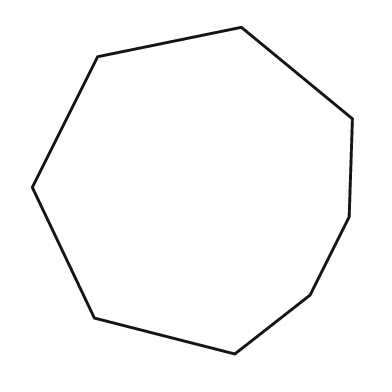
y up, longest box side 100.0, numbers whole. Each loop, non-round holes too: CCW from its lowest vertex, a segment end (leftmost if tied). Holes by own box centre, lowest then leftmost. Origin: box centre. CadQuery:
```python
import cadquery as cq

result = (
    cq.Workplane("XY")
    .moveTo(13.0, -50.0)
    .lineTo(36.0, -32.0)
    .lineTo(48.0, -8.0)
    .lineTo(49.0, 22.0)
    .lineTo(15.0, 50.0)
    .lineTo(-29.0, 41.0)
    .lineTo(-49.0, 1.0)
    .lineTo(-30.0, -39.0)
    .close()
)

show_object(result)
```